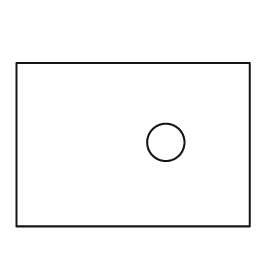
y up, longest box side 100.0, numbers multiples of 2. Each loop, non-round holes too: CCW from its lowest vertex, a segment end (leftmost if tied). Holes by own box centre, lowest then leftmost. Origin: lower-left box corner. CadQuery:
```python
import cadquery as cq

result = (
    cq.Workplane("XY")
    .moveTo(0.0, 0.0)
    .lineTo(100.0, 0.0)
    .lineTo(100.0, 70.0)
    .lineTo(0.0, 70.0)
    .close()
    .moveTo(64.0, 36.0)
    .circle(8.0)
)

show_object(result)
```